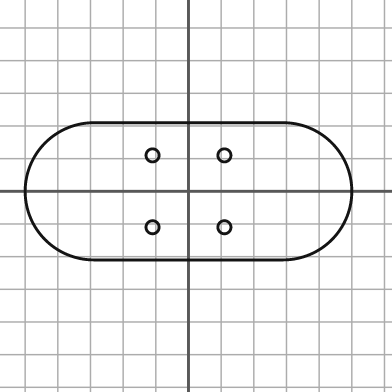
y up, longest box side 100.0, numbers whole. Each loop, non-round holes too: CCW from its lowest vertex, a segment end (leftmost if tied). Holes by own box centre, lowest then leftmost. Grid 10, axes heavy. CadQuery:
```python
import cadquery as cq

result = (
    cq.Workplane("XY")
    .moveTo(-29.0, -21.0)
    .lineTo(29.0, -21.0)
    .threePointArc((50.0, 0.0), (29.0, 21.0))
    .lineTo(-29.0, 21.0)
    .threePointArc((-50.0, 0.0), (-29.0, -21.0))
    .close()
    .moveTo(-11.0, -11.0)
    .circle(2.0)
    .moveTo(11.0, -11.0)
    .circle(2.0)
    .moveTo(-11.0, 11.0)
    .circle(2.0)
    .moveTo(11.0, 11.0)
    .circle(2.0)
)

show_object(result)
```